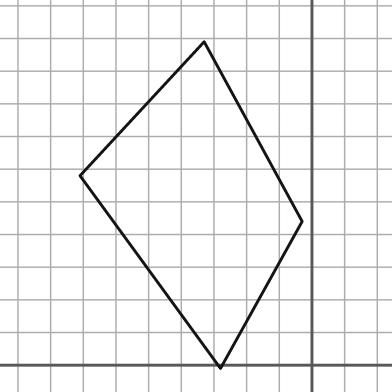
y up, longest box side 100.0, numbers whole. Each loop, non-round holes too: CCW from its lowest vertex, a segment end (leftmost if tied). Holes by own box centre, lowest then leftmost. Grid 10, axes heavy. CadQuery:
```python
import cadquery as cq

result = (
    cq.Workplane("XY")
    .moveTo(-28.0, -1.0)
    .lineTo(-3.0, 44.0)
    .lineTo(-33.0, 99.0)
    .lineTo(-71.0, 58.0)
    .close()
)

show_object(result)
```